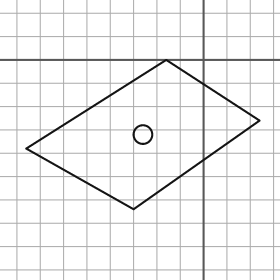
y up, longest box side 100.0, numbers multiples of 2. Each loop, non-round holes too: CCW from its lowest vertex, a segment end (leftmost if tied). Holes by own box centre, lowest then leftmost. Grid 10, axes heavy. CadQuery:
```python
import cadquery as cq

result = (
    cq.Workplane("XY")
    .moveTo(-30.0, -64.0)
    .lineTo(24.0, -26.0)
    .lineTo(-16.0, 0.0)
    .lineTo(-76.0, -38.0)
    .close()
    .moveTo(-26.0, -32.0)
    .circle(4.0)
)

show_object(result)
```